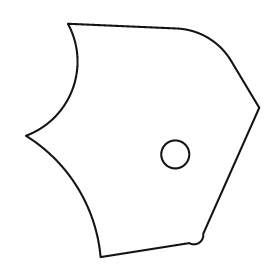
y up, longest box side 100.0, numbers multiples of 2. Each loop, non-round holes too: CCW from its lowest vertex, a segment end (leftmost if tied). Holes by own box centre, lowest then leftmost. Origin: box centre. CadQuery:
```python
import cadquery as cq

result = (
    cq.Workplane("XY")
    .moveTo(-18.0, -50.0)
    .lineTo(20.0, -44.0)
    .threePointArc((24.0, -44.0), (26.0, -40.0))
    .lineTo(50.0, 14.0)
    .lineTo(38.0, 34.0)
    .threePointArc((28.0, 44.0), (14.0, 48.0))
    .lineTo(-32.0, 50.0)
    .threePointArc((-30.0, 22.0), (-50.0, 2.0))
    .threePointArc((-28.0, -20.0), (-18.0, -50.0))
    .close()
    .moveTo(14.0, -6.0)
    .circle(6.0)
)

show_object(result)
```